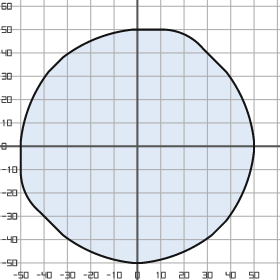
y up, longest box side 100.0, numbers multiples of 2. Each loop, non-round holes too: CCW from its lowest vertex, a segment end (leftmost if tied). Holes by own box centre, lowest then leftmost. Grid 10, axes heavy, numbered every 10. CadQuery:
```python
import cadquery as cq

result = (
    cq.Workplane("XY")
    .moveTo(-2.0, -50.0)
    .lineTo(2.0, -50.0)
    .threePointArc((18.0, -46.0), (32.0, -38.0))
    .lineTo(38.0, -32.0)
    .threePointArc((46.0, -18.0), (50.0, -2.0))
    .lineTo(50.0, 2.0)
    .threePointArc((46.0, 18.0), (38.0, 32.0))
    .lineTo(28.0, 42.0)
    .threePointArc((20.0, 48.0), (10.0, 50.0))
    .lineTo(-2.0, 50.0)
    .threePointArc((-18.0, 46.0), (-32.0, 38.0))
    .lineTo(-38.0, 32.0)
    .threePointArc((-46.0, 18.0), (-50.0, 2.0))
    .lineTo(-50.0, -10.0)
    .threePointArc((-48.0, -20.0), (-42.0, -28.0))
    .lineTo(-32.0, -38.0)
    .threePointArc((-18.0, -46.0), (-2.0, -50.0))
    .close()
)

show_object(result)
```